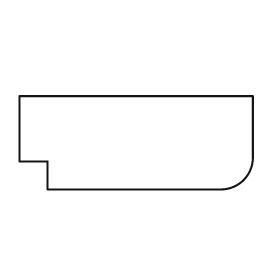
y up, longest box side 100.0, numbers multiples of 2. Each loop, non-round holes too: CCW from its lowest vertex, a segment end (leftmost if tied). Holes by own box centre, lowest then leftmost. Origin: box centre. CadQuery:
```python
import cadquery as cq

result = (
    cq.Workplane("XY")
    .moveTo(-38.0, -20.0)
    .lineTo(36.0, -20.0)
    .threePointArc((46.0, -16.0), (50.0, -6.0))
    .lineTo(50.0, 20.0)
    .lineTo(-50.0, 20.0)
    .lineTo(-50.0, -8.0)
    .lineTo(-38.0, -8.0)
    .close()
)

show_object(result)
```